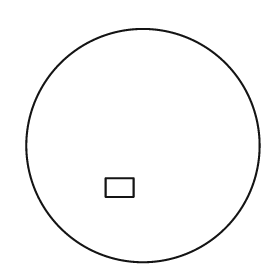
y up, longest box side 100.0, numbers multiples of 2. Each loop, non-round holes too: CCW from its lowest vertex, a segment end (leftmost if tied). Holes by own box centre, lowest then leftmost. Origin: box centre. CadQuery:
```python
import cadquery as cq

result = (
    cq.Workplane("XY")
    .moveTo(0.0, 0.0)
    .circle(50.0)
    .moveTo(-16.0, -22.0)
    .lineTo(-4.0, -22.0)
    .lineTo(-4.0, -14.0)
    .lineTo(-16.0, -14.0)
    .close()
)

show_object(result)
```